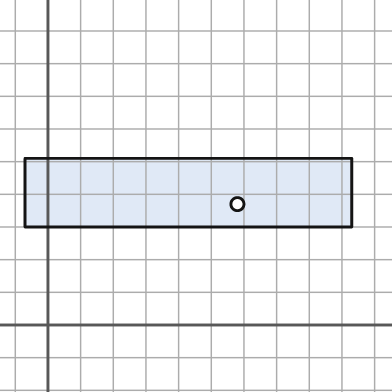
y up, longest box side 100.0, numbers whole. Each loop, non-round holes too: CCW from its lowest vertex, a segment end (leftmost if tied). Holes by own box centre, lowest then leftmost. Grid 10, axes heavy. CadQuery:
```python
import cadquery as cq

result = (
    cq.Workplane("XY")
    .moveTo(-7.0, 30.0)
    .lineTo(93.0, 30.0)
    .lineTo(93.0, 51.0)
    .lineTo(-7.0, 51.0)
    .close()
    .moveTo(58.0, 37.0)
    .circle(2.0)
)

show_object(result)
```